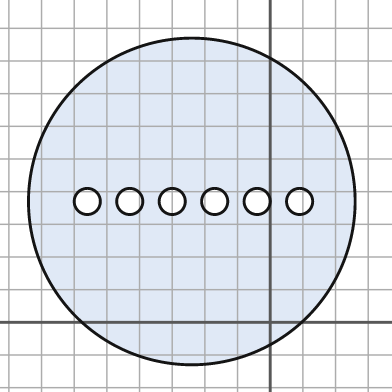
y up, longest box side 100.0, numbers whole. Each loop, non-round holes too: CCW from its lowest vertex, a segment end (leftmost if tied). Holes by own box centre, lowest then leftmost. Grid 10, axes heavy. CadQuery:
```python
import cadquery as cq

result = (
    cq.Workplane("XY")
    .moveTo(-24.0, 37.0)
    .circle(50.0)
    .moveTo(-56.0, 37.0)
    .circle(4.0)
    .moveTo(-43.0, 37.0)
    .circle(4.0)
    .moveTo(-30.0, 37.0)
    .circle(4.0)
    .moveTo(-17.0, 37.0)
    .circle(4.0)
    .moveTo(-4.0, 37.0)
    .circle(4.0)
    .moveTo(9.0, 37.0)
    .circle(4.0)
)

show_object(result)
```